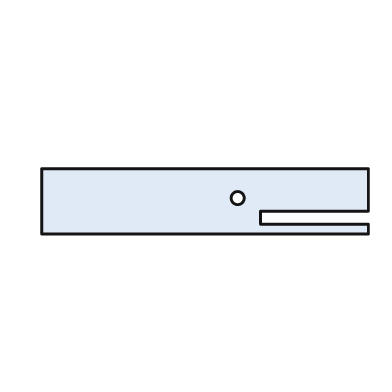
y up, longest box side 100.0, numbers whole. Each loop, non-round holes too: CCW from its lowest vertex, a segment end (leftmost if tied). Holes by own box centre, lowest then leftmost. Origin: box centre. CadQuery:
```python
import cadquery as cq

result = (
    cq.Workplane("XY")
    .moveTo(-50.0, -10.0)
    .lineTo(50.0, -10.0)
    .lineTo(50.0, -7.0)
    .lineTo(17.0, -7.0)
    .lineTo(17.0, -3.0)
    .lineTo(50.0, -3.0)
    .lineTo(50.0, 10.0)
    .lineTo(-50.0, 10.0)
    .close()
    .moveTo(10.0, 1.0)
    .circle(2.0)
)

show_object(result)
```